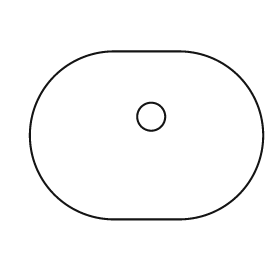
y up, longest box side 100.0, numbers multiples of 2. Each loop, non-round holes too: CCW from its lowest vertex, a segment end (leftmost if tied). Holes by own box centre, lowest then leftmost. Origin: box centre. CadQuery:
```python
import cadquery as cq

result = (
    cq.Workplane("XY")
    .moveTo(-14.0, -36.0)
    .lineTo(14.0, -36.0)
    .threePointArc((50.0, 0.0), (14.0, 36.0))
    .lineTo(-14.0, 36.0)
    .threePointArc((-50.0, 0.0), (-14.0, -36.0))
    .close()
    .moveTo(2.0, 8.0)
    .circle(6.0)
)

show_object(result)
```